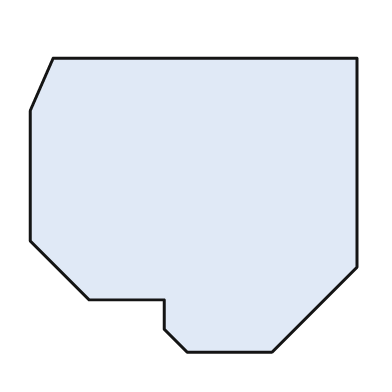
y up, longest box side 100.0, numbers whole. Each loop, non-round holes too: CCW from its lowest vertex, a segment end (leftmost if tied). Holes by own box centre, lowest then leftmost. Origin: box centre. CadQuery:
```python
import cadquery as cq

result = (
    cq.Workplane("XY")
    .moveTo(-2.0, -45.0)
    .lineTo(24.0, -45.0)
    .lineTo(50.0, -19.0)
    .lineTo(50.0, 45.0)
    .lineTo(-43.0, 45.0)
    .lineTo(-50.0, 29.0)
    .lineTo(-50.0, -11.0)
    .lineTo(-32.0, -29.0)
    .lineTo(-9.0, -29.0)
    .lineTo(-9.0, -38.0)
    .close()
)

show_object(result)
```